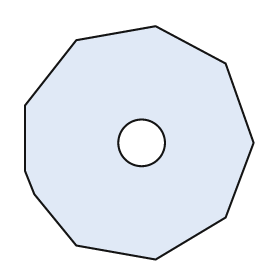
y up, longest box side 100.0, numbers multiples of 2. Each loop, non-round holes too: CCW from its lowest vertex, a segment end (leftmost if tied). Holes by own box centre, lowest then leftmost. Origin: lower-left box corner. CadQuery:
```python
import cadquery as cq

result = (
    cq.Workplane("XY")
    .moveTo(56.0, 0.0)
    .lineTo(86.0, 18.0)
    .lineTo(98.0, 50.0)
    .lineTo(86.0, 84.0)
    .lineTo(56.0, 100.0)
    .lineTo(22.0, 94.0)
    .lineTo(0.0, 66.0)
    .lineTo(0.0, 38.0)
    .lineTo(4.0, 28.0)
    .lineTo(22.0, 6.0)
    .close()
    .moveTo(50.0, 50.0)
    .circle(10.0)
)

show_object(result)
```